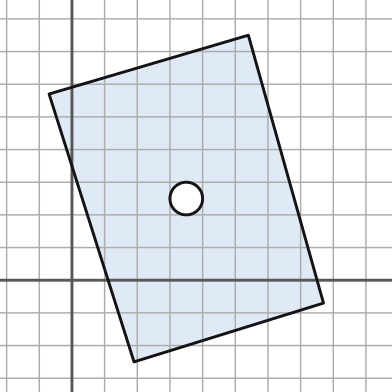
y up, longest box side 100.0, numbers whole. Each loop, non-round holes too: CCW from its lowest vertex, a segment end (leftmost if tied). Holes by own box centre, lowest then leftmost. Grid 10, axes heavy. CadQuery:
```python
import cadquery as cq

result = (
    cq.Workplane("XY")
    .moveTo(19.0, -25.0)
    .lineTo(77.0, -7.0)
    .lineTo(54.0, 75.0)
    .lineTo(-7.0, 57.0)
    .close()
    .moveTo(35.0, 25.0)
    .circle(5.0)
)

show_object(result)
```